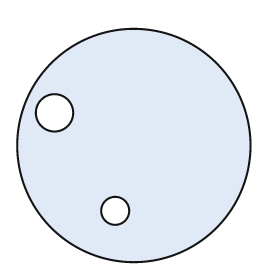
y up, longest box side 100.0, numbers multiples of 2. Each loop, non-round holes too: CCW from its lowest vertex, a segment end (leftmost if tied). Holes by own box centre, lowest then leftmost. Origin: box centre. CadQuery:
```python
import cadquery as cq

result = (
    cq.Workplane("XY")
    .moveTo(0.0, 0.0)
    .circle(50.0)
    .moveTo(-8.0, -28.0)
    .circle(6.0)
    .moveTo(-34.0, 14.0)
    .circle(8.0)
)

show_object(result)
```